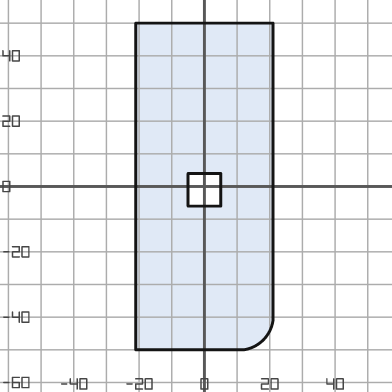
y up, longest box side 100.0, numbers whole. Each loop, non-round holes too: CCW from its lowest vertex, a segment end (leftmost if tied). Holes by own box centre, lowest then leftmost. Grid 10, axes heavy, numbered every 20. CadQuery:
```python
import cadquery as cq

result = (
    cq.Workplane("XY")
    .moveTo(-21.0, -50.0)
    .lineTo(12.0, -50.0)
    .threePointArc((18.0, -47.0), (21.0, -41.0))
    .lineTo(21.0, 50.0)
    .lineTo(-21.0, 50.0)
    .close()
    .moveTo(-5.0, -6.0)
    .lineTo(5.0, -6.0)
    .lineTo(5.0, 4.0)
    .lineTo(-5.0, 4.0)
    .close()
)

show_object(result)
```